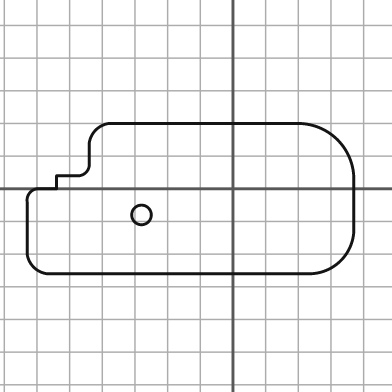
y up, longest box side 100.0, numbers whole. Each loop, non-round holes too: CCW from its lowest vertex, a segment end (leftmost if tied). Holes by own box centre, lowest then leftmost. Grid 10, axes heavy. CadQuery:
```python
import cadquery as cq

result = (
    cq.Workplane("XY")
    .moveTo(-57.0, -26.0)
    .lineTo(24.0, -26.0)
    .threePointArc((33.0, -22.0), (37.0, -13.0))
    .lineTo(37.0, 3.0)
    .threePointArc((32.0, 15.0), (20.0, 20.0))
    .lineTo(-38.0, 20.0)
    .threePointArc((-42.0, 18.0), (-44.0, 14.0))
    .lineTo(-44.0, 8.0)
    .threePointArc((-45.0, 5.0), (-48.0, 4.0))
    .lineTo(-54.0, 4.0)
    .lineTo(-54.0, 0.0)
    .lineTo(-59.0, 0.0)
    .threePointArc((-62.0, -1.0), (-63.0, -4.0))
    .lineTo(-63.0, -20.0)
    .threePointArc((-61.0, -24.0), (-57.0, -26.0))
    .close()
    .moveTo(-28.0, -8.0)
    .circle(3.0)
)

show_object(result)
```